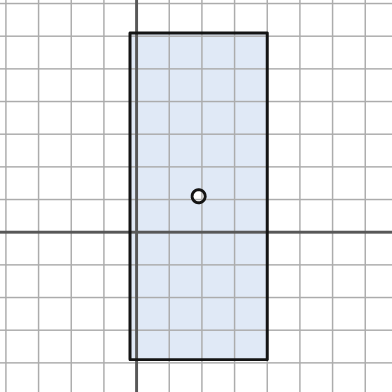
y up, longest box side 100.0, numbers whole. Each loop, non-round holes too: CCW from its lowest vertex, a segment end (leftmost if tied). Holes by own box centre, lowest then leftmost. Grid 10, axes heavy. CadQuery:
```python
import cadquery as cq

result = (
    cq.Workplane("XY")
    .moveTo(-2.0, -39.0)
    .lineTo(40.0, -39.0)
    .lineTo(40.0, 61.0)
    .lineTo(-2.0, 61.0)
    .close()
    .moveTo(19.0, 11.0)
    .circle(2.0)
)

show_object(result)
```